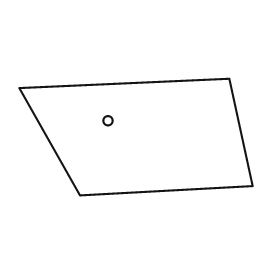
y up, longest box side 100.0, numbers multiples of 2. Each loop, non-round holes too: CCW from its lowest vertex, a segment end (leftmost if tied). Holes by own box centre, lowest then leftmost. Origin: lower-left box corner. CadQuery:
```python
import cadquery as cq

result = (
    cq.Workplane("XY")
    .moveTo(26.0, 0.0)
    .lineTo(100.0, 4.0)
    .lineTo(90.0, 50.0)
    .lineTo(0.0, 46.0)
    .close()
    .moveTo(38.0, 32.0)
    .circle(2.0)
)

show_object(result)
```